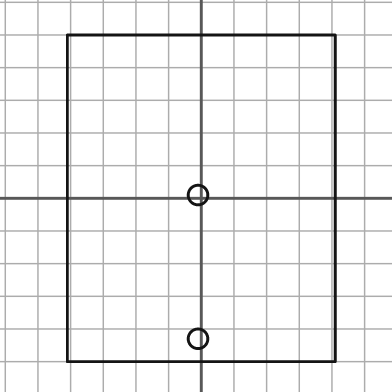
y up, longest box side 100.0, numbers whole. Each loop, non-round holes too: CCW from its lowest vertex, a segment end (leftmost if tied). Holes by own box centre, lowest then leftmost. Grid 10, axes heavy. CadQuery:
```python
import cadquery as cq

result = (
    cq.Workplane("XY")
    .moveTo(-41.0, -50.0)
    .lineTo(41.0, -50.0)
    .lineTo(41.0, 50.0)
    .lineTo(-41.0, 50.0)
    .close()
    .moveTo(-1.0, -43.0)
    .circle(3.0)
    .moveTo(-1.0, 1.0)
    .circle(3.0)
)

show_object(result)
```